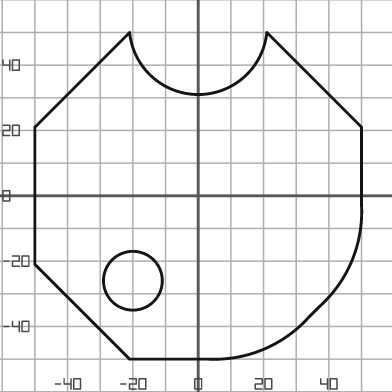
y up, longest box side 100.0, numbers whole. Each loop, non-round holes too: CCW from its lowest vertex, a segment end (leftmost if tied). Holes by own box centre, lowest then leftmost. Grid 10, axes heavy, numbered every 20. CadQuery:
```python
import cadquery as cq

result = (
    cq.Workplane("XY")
    .moveTo(-21.0, -50.0)
    .lineTo(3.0, -50.0)
    .threePointArc((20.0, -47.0), (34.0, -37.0))
    .lineTo(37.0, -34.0)
    .threePointArc((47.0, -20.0), (50.0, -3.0))
    .lineTo(50.0, 21.0)
    .lineTo(21.0, 50.0)
    .threePointArc((0.0, 31.0), (-21.0, 50.0))
    .lineTo(-50.0, 21.0)
    .lineTo(-50.0, -21.0)
    .close()
    .moveTo(-20.0, -26.0)
    .circle(9.0)
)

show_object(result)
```